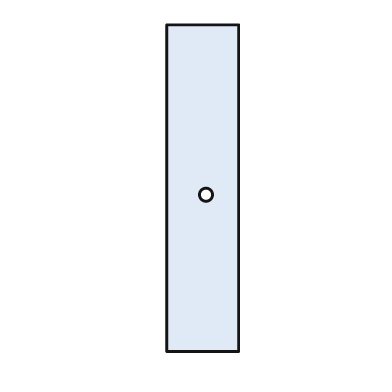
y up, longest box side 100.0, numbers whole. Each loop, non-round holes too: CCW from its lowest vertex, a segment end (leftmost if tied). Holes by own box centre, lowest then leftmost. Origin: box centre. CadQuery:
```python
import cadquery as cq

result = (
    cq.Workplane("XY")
    .moveTo(-11.0, -50.0)
    .lineTo(11.0, -50.0)
    .lineTo(11.0, 50.0)
    .lineTo(-11.0, 50.0)
    .close()
    .moveTo(1.0, -2.0)
    .circle(2.0)
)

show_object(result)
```